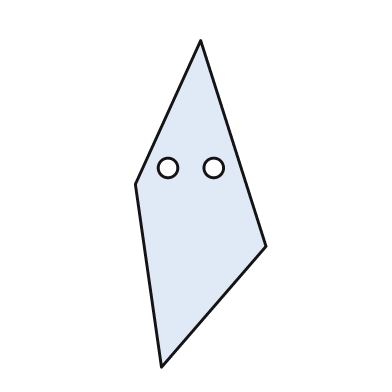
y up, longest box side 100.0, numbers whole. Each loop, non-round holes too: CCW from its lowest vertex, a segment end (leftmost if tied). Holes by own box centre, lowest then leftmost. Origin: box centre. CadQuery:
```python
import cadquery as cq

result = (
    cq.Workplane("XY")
    .moveTo(-12.0, -50.0)
    .lineTo(20.0, -13.0)
    .lineTo(0.0, 50.0)
    .lineTo(-20.0, 6.0)
    .close()
    .moveTo(-10.0, 11.0)
    .circle(3.0)
    .moveTo(4.0, 11.0)
    .circle(3.0)
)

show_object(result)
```